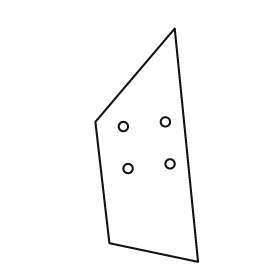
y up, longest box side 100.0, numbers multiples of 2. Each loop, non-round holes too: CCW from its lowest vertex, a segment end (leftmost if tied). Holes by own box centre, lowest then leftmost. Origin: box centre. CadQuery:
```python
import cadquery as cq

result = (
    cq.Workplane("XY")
    .moveTo(22.0, -50.0)
    .lineTo(12.0, 50.0)
    .lineTo(-22.0, 10.0)
    .lineTo(-16.0, -42.0)
    .close()
    .moveTo(-8.0, -10.0)
    .circle(2.0)
    .moveTo(10.0, -8.0)
    .circle(2.0)
    .moveTo(-10.0, 8.0)
    .circle(2.0)
    .moveTo(8.0, 10.0)
    .circle(2.0)
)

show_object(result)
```